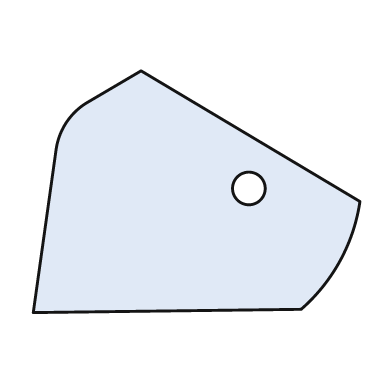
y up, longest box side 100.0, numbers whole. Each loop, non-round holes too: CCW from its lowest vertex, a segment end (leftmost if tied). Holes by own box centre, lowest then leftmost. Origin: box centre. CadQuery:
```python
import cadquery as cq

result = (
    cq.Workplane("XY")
    .moveTo(-50.0, -37.0)
    .lineTo(32.0, -36.0)
    .threePointArc((44.0, -21.0), (50.0, -3.0))
    .lineTo(-17.0, 37.0)
    .lineTo(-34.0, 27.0)
    .threePointArc((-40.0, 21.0), (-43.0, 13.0))
    .close()
    .moveTo(16.0, 1.0)
    .circle(5.0)
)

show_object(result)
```